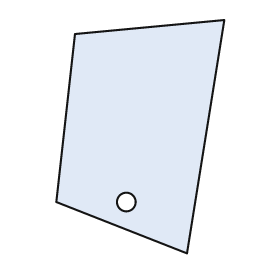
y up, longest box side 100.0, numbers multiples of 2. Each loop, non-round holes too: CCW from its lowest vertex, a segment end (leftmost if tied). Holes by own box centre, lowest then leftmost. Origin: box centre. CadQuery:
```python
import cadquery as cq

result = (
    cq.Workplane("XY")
    .moveTo(20.0, -50.0)
    .lineTo(36.0, 50.0)
    .lineTo(-28.0, 44.0)
    .lineTo(-36.0, -28.0)
    .close()
    .moveTo(-6.0, -28.0)
    .circle(4.0)
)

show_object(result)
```